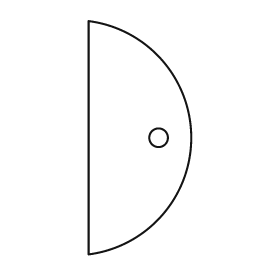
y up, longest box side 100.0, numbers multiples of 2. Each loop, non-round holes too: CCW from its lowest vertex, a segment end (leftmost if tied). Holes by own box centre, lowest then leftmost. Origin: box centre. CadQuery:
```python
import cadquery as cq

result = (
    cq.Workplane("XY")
    .moveTo(-22.0, -50.0)
    .threePointArc((22.0, 0.0), (-22.0, 50.0))
    .close()
    .moveTo(8.0, 0.0)
    .circle(4.0)
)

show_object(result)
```